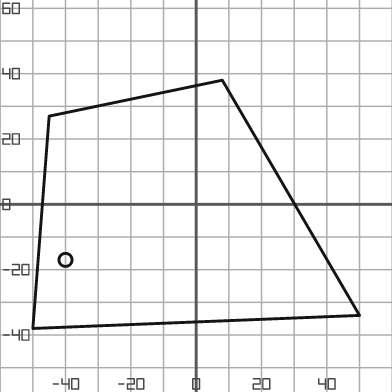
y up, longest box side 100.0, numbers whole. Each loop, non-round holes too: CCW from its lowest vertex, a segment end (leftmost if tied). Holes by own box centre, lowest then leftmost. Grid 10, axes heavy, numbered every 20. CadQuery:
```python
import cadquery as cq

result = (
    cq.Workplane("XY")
    .moveTo(-50.0, -38.0)
    .lineTo(50.0, -34.0)
    .lineTo(8.0, 38.0)
    .lineTo(-45.0, 27.0)
    .close()
    .moveTo(-40.0, -17.0)
    .circle(2.0)
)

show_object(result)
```